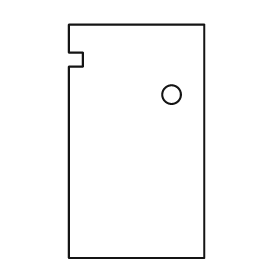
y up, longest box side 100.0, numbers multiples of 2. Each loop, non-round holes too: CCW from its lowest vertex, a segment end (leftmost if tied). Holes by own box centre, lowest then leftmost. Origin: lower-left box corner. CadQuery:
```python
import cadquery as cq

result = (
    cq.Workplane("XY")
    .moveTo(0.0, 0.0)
    .lineTo(58.0, 0.0)
    .lineTo(58.0, 100.0)
    .lineTo(0.0, 100.0)
    .lineTo(0.0, 88.0)
    .lineTo(6.0, 88.0)
    .lineTo(6.0, 82.0)
    .lineTo(0.0, 82.0)
    .close()
    .moveTo(44.0, 70.0)
    .circle(4.0)
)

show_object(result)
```